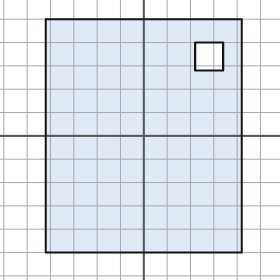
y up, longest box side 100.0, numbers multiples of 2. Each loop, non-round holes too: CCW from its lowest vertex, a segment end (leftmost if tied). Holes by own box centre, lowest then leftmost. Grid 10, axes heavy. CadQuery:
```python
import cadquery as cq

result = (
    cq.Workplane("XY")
    .moveTo(-42.0, -50.0)
    .lineTo(42.0, -50.0)
    .lineTo(42.0, 50.0)
    .lineTo(-42.0, 50.0)
    .close()
    .moveTo(22.0, 28.0)
    .lineTo(34.0, 28.0)
    .lineTo(34.0, 40.0)
    .lineTo(22.0, 40.0)
    .close()
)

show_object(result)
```